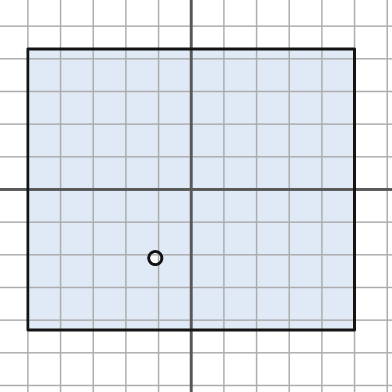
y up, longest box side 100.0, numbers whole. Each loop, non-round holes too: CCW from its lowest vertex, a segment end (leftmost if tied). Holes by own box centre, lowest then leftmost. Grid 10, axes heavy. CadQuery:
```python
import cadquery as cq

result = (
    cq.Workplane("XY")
    .moveTo(-50.0, -43.0)
    .lineTo(50.0, -43.0)
    .lineTo(50.0, 43.0)
    .lineTo(-50.0, 43.0)
    .close()
    .moveTo(-11.0, -21.0)
    .circle(2.0)
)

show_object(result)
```